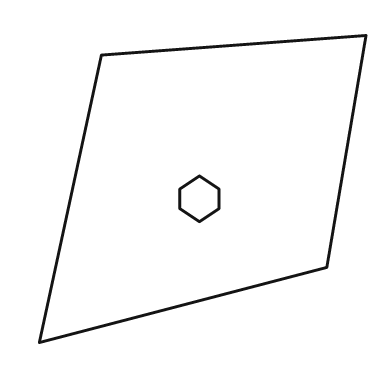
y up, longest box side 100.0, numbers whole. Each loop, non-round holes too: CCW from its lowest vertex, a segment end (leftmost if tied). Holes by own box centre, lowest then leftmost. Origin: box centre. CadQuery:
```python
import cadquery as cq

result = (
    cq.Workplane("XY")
    .moveTo(-50.0, -47.0)
    .lineTo(38.0, -24.0)
    .lineTo(50.0, 47.0)
    .lineTo(-31.0, 41.0)
    .close()
    .moveTo(-1.0, -10.0)
    .lineTo(5.0, -6.0)
    .lineTo(5.0, 0.0)
    .lineTo(-1.0, 4.0)
    .lineTo(-7.0, 0.0)
    .lineTo(-7.0, -6.0)
    .close()
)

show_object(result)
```